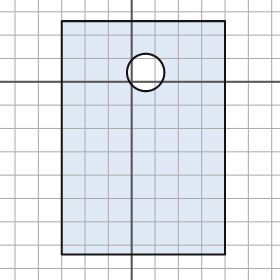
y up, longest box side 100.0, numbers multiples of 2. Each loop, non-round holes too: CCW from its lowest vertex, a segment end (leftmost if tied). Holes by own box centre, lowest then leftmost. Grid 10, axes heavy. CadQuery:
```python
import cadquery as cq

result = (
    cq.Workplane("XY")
    .moveTo(-30.0, -74.0)
    .lineTo(40.0, -74.0)
    .lineTo(40.0, 26.0)
    .lineTo(-30.0, 26.0)
    .close()
    .moveTo(6.0, 4.0)
    .circle(8.0)
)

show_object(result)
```